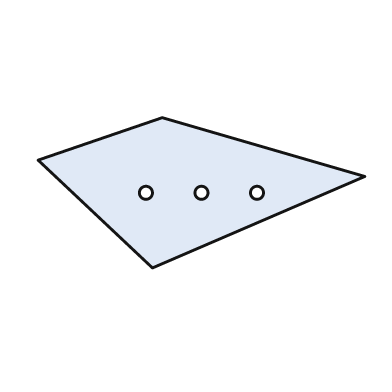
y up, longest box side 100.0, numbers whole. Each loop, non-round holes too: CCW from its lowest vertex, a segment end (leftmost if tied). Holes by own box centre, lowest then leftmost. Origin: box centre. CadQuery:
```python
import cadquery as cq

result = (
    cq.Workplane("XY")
    .moveTo(-15.0, -23.0)
    .lineTo(50.0, 5.0)
    .lineTo(-12.0, 23.0)
    .lineTo(-50.0, 10.0)
    .close()
    .moveTo(-17.0, 0.0)
    .circle(2.0)
    .moveTo(0.0, 0.0)
    .circle(2.0)
    .moveTo(17.0, 0.0)
    .circle(2.0)
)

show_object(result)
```